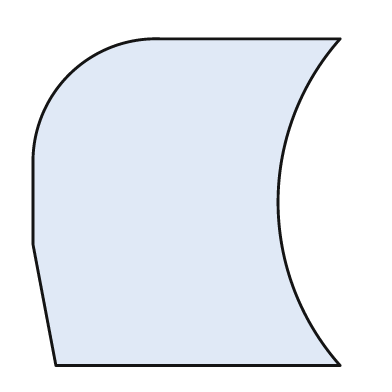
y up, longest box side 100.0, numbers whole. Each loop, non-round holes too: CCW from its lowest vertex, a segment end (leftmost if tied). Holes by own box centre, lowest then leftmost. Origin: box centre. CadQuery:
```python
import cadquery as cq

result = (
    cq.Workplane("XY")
    .moveTo(-40.0, -50.0)
    .lineTo(47.0, -50.0)
    .threePointArc((28.0, 0.0), (47.0, 50.0))
    .lineTo(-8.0, 50.0)
    .threePointArc((-36.0, 39.0), (-47.0, 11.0))
    .lineTo(-47.0, -13.0)
    .close()
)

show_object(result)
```